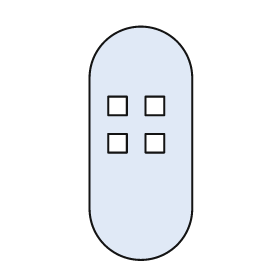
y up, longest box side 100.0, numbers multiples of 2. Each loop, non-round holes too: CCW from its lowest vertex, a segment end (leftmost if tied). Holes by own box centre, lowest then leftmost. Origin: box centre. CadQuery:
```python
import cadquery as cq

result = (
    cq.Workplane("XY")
    .moveTo(-22.0, -28.0)
    .threePointArc((0.0, -50.0), (22.0, -28.0))
    .lineTo(22.0, 28.0)
    .threePointArc((0.0, 50.0), (-22.0, 28.0))
    .close()
    .moveTo(-14.0, -4.0)
    .lineTo(-6.0, -4.0)
    .lineTo(-6.0, 4.0)
    .lineTo(-14.0, 4.0)
    .close()
    .moveTo(2.0, -4.0)
    .lineTo(10.0, -4.0)
    .lineTo(10.0, 4.0)
    .lineTo(2.0, 4.0)
    .close()
    .moveTo(-14.0, 12.0)
    .lineTo(-6.0, 12.0)
    .lineTo(-6.0, 20.0)
    .lineTo(-14.0, 20.0)
    .close()
    .moveTo(2.0, 12.0)
    .lineTo(10.0, 12.0)
    .lineTo(10.0, 20.0)
    .lineTo(2.0, 20.0)
    .close()
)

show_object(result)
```